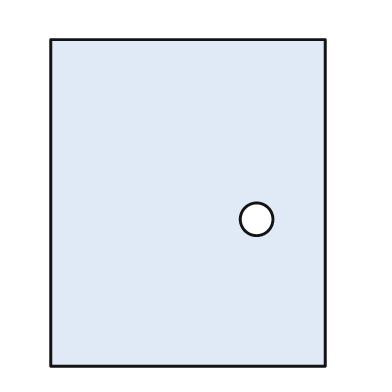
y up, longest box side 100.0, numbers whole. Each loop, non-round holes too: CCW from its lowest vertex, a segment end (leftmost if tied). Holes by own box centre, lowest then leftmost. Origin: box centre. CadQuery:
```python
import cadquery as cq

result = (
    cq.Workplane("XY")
    .moveTo(-42.0, -50.0)
    .lineTo(42.0, -50.0)
    .lineTo(42.0, 50.0)
    .lineTo(-42.0, 50.0)
    .close()
    .moveTo(21.0, -5.0)
    .circle(5.0)
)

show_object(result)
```